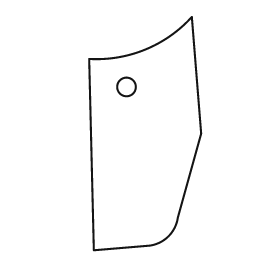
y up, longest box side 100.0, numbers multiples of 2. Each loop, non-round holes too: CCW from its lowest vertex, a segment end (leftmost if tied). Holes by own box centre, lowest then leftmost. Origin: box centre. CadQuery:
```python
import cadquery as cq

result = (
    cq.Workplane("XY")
    .moveTo(-22.0, -50.0)
    .lineTo(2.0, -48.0)
    .threePointArc((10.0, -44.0), (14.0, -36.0))
    .lineTo(24.0, 0.0)
    .lineTo(20.0, 50.0)
    .threePointArc((0.0, 36.0), (-24.0, 32.0))
    .close()
    .moveTo(-8.0, 20.0)
    .circle(4.0)
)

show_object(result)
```